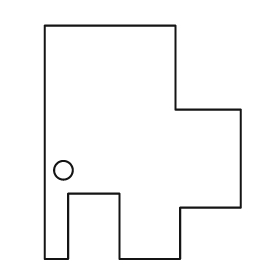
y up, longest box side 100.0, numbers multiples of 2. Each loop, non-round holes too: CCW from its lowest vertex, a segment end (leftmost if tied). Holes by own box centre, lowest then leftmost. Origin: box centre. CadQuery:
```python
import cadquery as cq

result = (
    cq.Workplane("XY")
    .moveTo(-42.0, -50.0)
    .lineTo(-32.0, -50.0)
    .lineTo(-32.0, -22.0)
    .lineTo(-10.0, -22.0)
    .lineTo(-10.0, -50.0)
    .lineTo(16.0, -50.0)
    .lineTo(16.0, -28.0)
    .lineTo(42.0, -28.0)
    .lineTo(42.0, 14.0)
    .lineTo(14.0, 14.0)
    .lineTo(14.0, 50.0)
    .lineTo(-42.0, 50.0)
    .close()
    .moveTo(-34.0, -12.0)
    .circle(4.0)
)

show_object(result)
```